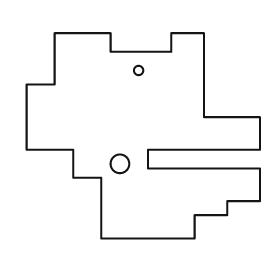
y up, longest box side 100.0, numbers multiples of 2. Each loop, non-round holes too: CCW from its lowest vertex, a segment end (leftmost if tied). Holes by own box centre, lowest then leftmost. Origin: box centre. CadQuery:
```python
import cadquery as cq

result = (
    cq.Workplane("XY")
    .moveTo(-18.0, -44.0)
    .lineTo(22.0, -44.0)
    .lineTo(22.0, -34.0)
    .lineTo(36.0, -34.0)
    .lineTo(36.0, -28.0)
    .lineTo(50.0, -28.0)
    .lineTo(50.0, -14.0)
    .lineTo(2.0, -14.0)
    .lineTo(2.0, -6.0)
    .lineTo(50.0, -6.0)
    .lineTo(50.0, 8.0)
    .lineTo(26.0, 8.0)
    .lineTo(26.0, 44.0)
    .lineTo(12.0, 44.0)
    .lineTo(12.0, 36.0)
    .lineTo(-14.0, 36.0)
    .lineTo(-14.0, 44.0)
    .lineTo(-38.0, 44.0)
    .lineTo(-38.0, 22.0)
    .lineTo(-50.0, 22.0)
    .lineTo(-50.0, -6.0)
    .lineTo(-30.0, -6.0)
    .lineTo(-30.0, -18.0)
    .lineTo(-18.0, -18.0)
    .close()
    .moveTo(-10.0, -12.0)
    .circle(4.0)
    .moveTo(-2.0, 28.0)
    .circle(2.0)
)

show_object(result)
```